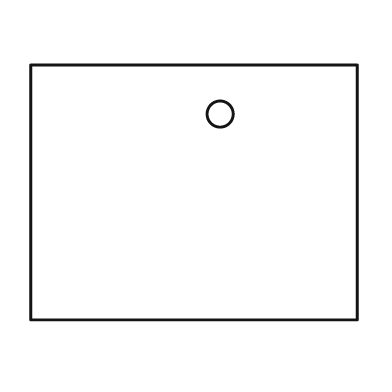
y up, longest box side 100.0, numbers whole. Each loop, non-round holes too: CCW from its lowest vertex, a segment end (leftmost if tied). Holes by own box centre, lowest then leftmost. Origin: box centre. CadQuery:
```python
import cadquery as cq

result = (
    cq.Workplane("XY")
    .moveTo(-50.0, -39.0)
    .lineTo(50.0, -39.0)
    .lineTo(50.0, 39.0)
    .lineTo(-50.0, 39.0)
    .close()
    .moveTo(8.0, 24.0)
    .circle(4.0)
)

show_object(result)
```